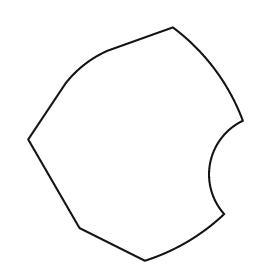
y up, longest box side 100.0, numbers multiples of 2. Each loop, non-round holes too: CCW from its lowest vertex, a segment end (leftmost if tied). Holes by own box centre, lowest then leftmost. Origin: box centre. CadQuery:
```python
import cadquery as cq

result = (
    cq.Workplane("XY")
    .moveTo(4.0, -50.0)
    .threePointArc((22.0, -42.0), (38.0, -30.0))
    .threePointArc((32.0, -8.0), (46.0, 10.0))
    .threePointArc((34.0, 32.0), (16.0, 50.0))
    .lineTo(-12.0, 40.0)
    .threePointArc((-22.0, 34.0), (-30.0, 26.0))
    .lineTo(-46.0, 2.0)
    .lineTo(-24.0, -36.0)
    .close()
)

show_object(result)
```